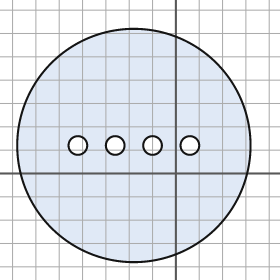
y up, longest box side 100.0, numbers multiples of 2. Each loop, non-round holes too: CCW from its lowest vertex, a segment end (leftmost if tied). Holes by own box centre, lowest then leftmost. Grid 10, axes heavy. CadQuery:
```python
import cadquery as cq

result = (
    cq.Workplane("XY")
    .moveTo(-18.0, 12.0)
    .circle(50.0)
    .moveTo(-42.0, 12.0)
    .circle(4.0)
    .moveTo(-26.0, 12.0)
    .circle(4.0)
    .moveTo(-10.0, 12.0)
    .circle(4.0)
    .moveTo(6.0, 12.0)
    .circle(4.0)
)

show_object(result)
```